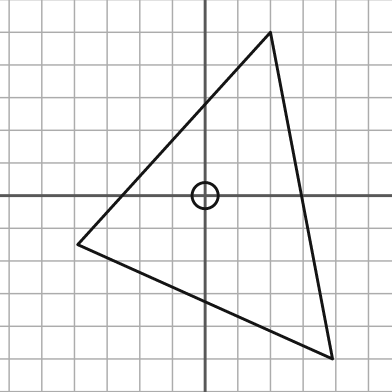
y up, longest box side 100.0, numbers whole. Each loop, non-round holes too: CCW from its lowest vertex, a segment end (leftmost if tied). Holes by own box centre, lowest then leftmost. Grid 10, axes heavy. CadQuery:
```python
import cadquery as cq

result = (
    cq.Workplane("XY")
    .moveTo(39.0, -50.0)
    .lineTo(20.0, 50.0)
    .lineTo(-39.0, -15.0)
    .close()
    .moveTo(0.0, 0.0)
    .circle(4.0)
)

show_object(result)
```